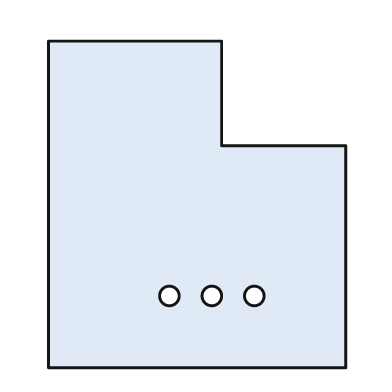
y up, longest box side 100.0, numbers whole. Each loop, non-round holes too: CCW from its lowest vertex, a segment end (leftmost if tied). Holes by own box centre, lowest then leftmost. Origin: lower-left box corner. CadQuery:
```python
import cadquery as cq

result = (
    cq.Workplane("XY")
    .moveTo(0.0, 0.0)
    .lineTo(91.0, 0.0)
    .lineTo(91.0, 68.0)
    .lineTo(53.0, 68.0)
    .lineTo(53.0, 100.0)
    .lineTo(0.0, 100.0)
    .close()
    .moveTo(37.0, 22.0)
    .circle(3.0)
    .moveTo(50.0, 22.0)
    .circle(3.0)
    .moveTo(63.0, 22.0)
    .circle(3.0)
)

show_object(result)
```